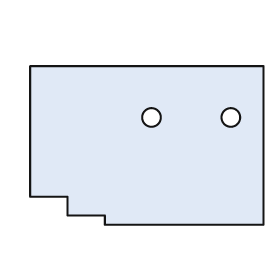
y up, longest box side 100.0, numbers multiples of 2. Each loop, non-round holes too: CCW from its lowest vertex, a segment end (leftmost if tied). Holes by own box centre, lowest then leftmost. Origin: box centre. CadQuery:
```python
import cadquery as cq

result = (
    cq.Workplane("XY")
    .moveTo(-18.0, -34.0)
    .lineTo(50.0, -34.0)
    .lineTo(50.0, 34.0)
    .lineTo(-50.0, 34.0)
    .lineTo(-50.0, -22.0)
    .lineTo(-34.0, -22.0)
    .lineTo(-34.0, -30.0)
    .lineTo(-18.0, -30.0)
    .close()
    .moveTo(2.0, 12.0)
    .circle(4.0)
    .moveTo(36.0, 12.0)
    .circle(4.0)
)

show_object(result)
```